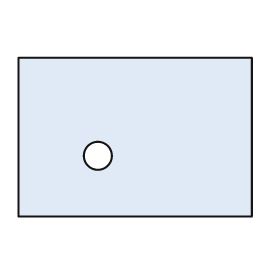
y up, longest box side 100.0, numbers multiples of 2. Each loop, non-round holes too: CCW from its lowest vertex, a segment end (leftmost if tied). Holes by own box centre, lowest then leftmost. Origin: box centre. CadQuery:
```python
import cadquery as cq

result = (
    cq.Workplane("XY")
    .moveTo(-50.0, -34.0)
    .lineTo(50.0, -34.0)
    .lineTo(50.0, 34.0)
    .lineTo(-50.0, 34.0)
    .close()
    .moveTo(-16.0, -8.0)
    .circle(6.0)
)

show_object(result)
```